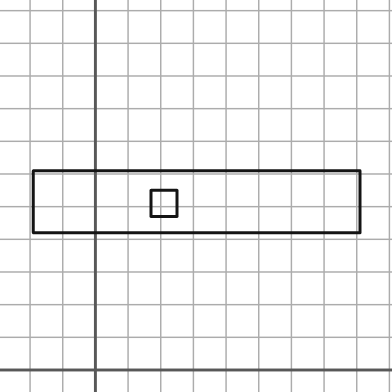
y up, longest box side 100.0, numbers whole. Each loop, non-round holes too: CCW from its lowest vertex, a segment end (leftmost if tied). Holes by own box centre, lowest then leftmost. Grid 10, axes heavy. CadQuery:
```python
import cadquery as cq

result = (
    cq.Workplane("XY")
    .moveTo(-19.0, 42.0)
    .lineTo(81.0, 42.0)
    .lineTo(81.0, 61.0)
    .lineTo(-19.0, 61.0)
    .close()
    .moveTo(17.0, 47.0)
    .lineTo(25.0, 47.0)
    .lineTo(25.0, 55.0)
    .lineTo(17.0, 55.0)
    .close()
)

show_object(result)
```